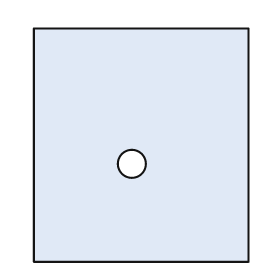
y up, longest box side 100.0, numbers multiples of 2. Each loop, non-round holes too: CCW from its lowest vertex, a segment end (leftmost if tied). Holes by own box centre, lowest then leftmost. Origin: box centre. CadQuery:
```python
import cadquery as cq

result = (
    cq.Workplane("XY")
    .moveTo(-46.0, -50.0)
    .lineTo(46.0, -50.0)
    .lineTo(46.0, 50.0)
    .lineTo(-46.0, 50.0)
    .close()
    .moveTo(-4.0, -8.0)
    .circle(6.0)
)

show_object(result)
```